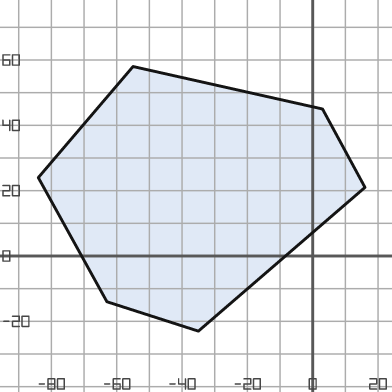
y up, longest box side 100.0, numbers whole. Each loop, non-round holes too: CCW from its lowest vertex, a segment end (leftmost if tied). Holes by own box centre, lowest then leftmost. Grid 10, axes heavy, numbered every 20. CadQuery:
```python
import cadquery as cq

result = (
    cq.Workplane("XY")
    .moveTo(-35.0, -23.0)
    .lineTo(16.0, 21.0)
    .lineTo(3.0, 45.0)
    .lineTo(-55.0, 58.0)
    .lineTo(-84.0, 24.0)
    .lineTo(-63.0, -14.0)
    .close()
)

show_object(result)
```